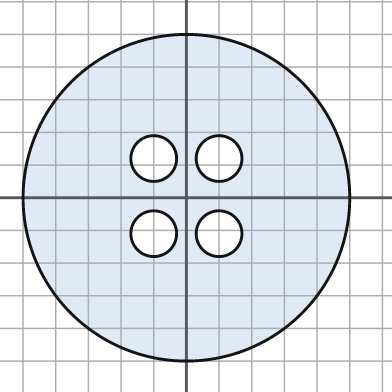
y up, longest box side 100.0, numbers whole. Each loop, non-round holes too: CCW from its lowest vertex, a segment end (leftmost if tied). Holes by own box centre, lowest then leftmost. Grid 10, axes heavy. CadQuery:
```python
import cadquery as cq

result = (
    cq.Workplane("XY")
    .moveTo(0.0, 0.0)
    .circle(50.0)
    .moveTo(-10.0, -11.0)
    .circle(7.0)
    .moveTo(10.0, -11.0)
    .circle(7.0)
    .moveTo(-10.0, 12.0)
    .circle(7.0)
    .moveTo(10.0, 12.0)
    .circle(7.0)
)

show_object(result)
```